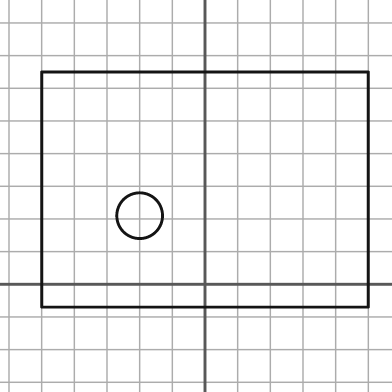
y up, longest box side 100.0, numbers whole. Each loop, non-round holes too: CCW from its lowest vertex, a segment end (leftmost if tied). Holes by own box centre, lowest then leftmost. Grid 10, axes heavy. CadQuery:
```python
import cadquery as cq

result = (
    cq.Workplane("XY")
    .moveTo(-50.0, -7.0)
    .lineTo(50.0, -7.0)
    .lineTo(50.0, 65.0)
    .lineTo(-50.0, 65.0)
    .close()
    .moveTo(-20.0, 21.0)
    .circle(7.0)
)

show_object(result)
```